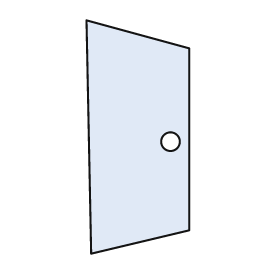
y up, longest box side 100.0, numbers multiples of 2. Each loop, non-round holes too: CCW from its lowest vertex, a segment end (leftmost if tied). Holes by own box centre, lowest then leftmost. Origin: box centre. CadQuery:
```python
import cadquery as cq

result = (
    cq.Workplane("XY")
    .moveTo(-20.0, -50.0)
    .lineTo(22.0, -40.0)
    .lineTo(22.0, 38.0)
    .lineTo(-22.0, 50.0)
    .close()
    .moveTo(14.0, -2.0)
    .circle(4.0)
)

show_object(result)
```